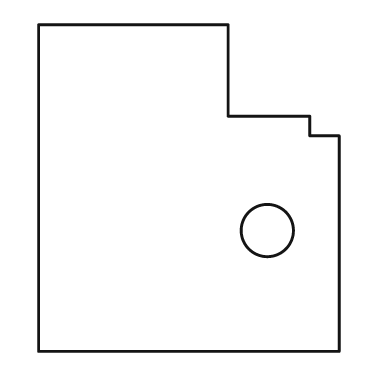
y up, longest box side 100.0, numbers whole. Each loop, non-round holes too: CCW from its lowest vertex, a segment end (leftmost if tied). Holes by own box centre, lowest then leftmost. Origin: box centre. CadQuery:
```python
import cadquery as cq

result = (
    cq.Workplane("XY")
    .moveTo(-46.0, -50.0)
    .lineTo(46.0, -50.0)
    .lineTo(46.0, 16.0)
    .lineTo(37.0, 16.0)
    .lineTo(37.0, 22.0)
    .lineTo(12.0, 22.0)
    .lineTo(12.0, 50.0)
    .lineTo(-46.0, 50.0)
    .close()
    .moveTo(24.0, -13.0)
    .circle(8.0)
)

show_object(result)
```